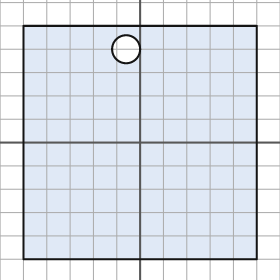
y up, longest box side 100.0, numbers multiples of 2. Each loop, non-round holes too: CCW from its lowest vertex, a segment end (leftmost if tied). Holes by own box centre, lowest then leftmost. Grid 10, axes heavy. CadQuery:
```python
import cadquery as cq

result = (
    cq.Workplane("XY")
    .moveTo(-50.0, -50.0)
    .lineTo(50.0, -50.0)
    .lineTo(50.0, 50.0)
    .lineTo(-50.0, 50.0)
    .close()
    .moveTo(-6.0, 40.0)
    .circle(6.0)
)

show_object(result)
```